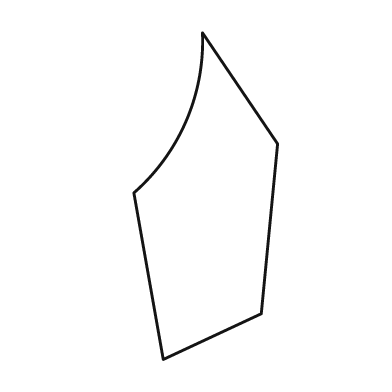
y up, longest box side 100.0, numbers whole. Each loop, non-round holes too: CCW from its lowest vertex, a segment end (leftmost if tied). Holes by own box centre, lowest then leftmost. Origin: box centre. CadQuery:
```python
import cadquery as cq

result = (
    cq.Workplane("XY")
    .moveTo(-13.0, -50.0)
    .lineTo(17.0, -36.0)
    .lineTo(22.0, 16.0)
    .lineTo(-1.0, 50.0)
    .threePointArc((-6.0, 23.0), (-22.0, 1.0))
    .close()
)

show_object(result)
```